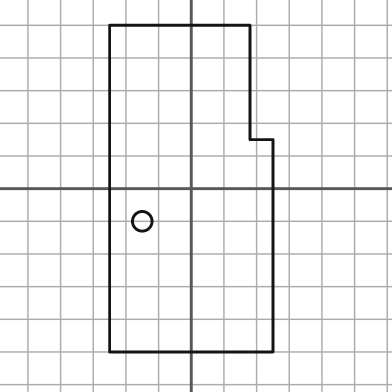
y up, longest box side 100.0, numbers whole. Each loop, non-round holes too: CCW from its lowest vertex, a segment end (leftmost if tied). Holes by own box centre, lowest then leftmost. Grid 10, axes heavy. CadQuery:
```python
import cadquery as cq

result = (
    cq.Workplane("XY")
    .moveTo(-25.0, -50.0)
    .lineTo(25.0, -50.0)
    .lineTo(25.0, 15.0)
    .lineTo(18.0, 15.0)
    .lineTo(18.0, 50.0)
    .lineTo(-25.0, 50.0)
    .close()
    .moveTo(-15.0, -10.0)
    .circle(3.0)
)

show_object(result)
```